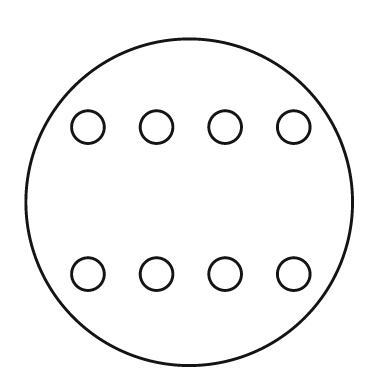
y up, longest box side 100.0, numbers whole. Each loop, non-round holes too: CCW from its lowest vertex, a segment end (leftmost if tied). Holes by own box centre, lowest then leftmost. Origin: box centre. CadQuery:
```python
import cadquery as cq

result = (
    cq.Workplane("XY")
    .moveTo(0.0, 0.0)
    .circle(50.0)
    .moveTo(-31.0, -22.0)
    .circle(5.0)
    .moveTo(-10.0, -22.0)
    .circle(5.0)
    .moveTo(11.0, -22.0)
    .circle(5.0)
    .moveTo(32.0, -22.0)
    .circle(5.0)
    .moveTo(-31.0, 23.0)
    .circle(5.0)
    .moveTo(-10.0, 23.0)
    .circle(5.0)
    .moveTo(11.0, 23.0)
    .circle(5.0)
    .moveTo(32.0, 23.0)
    .circle(5.0)
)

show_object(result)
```